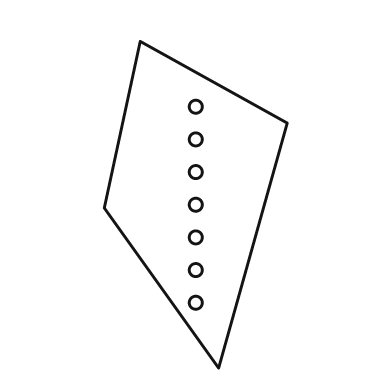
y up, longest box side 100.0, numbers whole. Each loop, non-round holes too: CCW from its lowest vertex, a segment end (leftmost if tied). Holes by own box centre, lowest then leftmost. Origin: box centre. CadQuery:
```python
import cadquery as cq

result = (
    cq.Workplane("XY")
    .moveTo(7.0, -50.0)
    .lineTo(28.0, 25.0)
    .lineTo(-17.0, 50.0)
    .lineTo(-28.0, -1.0)
    .close()
    .moveTo(0.0, -30.0)
    .circle(2.0)
    .moveTo(0.0, -20.0)
    .circle(2.0)
    .moveTo(0.0, -10.0)
    .circle(2.0)
    .moveTo(0.0, 0.0)
    .circle(2.0)
    .moveTo(0.0, 10.0)
    .circle(2.0)
    .moveTo(0.0, 20.0)
    .circle(2.0)
    .moveTo(0.0, 30.0)
    .circle(2.0)
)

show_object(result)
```